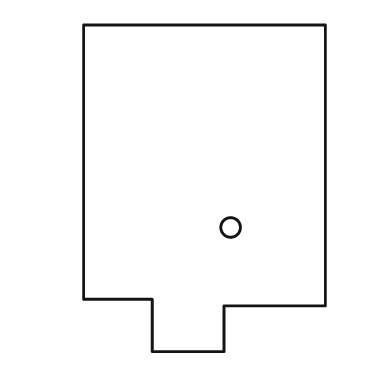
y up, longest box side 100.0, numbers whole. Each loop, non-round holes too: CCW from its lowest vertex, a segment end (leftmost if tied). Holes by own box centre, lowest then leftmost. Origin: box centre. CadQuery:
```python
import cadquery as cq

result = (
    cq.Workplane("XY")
    .moveTo(-16.0, -50.0)
    .lineTo(6.0, -50.0)
    .lineTo(6.0, -36.0)
    .lineTo(37.0, -36.0)
    .lineTo(37.0, 50.0)
    .lineTo(-37.0, 50.0)
    .lineTo(-37.0, -34.0)
    .lineTo(-16.0, -34.0)
    .close()
    .moveTo(8.0, -12.0)
    .circle(3.0)
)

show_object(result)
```